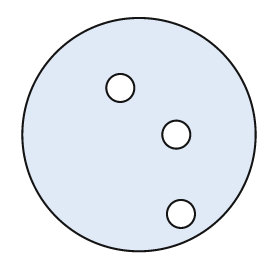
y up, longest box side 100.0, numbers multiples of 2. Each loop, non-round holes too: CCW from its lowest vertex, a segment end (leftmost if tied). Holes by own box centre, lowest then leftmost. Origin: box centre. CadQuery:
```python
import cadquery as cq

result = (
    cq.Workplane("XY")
    .moveTo(0.0, 0.0)
    .circle(50.0)
    .moveTo(18.0, -34.0)
    .circle(6.0)
    .moveTo(16.0, 0.0)
    .circle(6.0)
    .moveTo(-8.0, 20.0)
    .circle(6.0)
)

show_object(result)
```